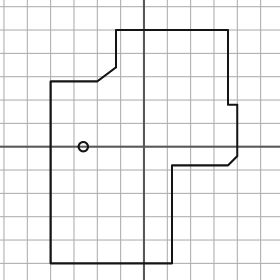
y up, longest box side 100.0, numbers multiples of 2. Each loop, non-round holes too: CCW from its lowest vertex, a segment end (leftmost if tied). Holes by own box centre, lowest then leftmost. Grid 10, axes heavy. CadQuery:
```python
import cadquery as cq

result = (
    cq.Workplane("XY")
    .moveTo(-40.0, -50.0)
    .lineTo(12.0, -50.0)
    .lineTo(12.0, -8.0)
    .lineTo(36.0, -8.0)
    .lineTo(40.0, -4.0)
    .lineTo(40.0, 18.0)
    .lineTo(36.0, 18.0)
    .lineTo(36.0, 50.0)
    .lineTo(-12.0, 50.0)
    .lineTo(-12.0, 34.0)
    .lineTo(-20.0, 28.0)
    .lineTo(-40.0, 28.0)
    .close()
    .moveTo(-26.0, 0.0)
    .circle(2.0)
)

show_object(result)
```